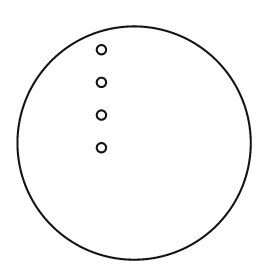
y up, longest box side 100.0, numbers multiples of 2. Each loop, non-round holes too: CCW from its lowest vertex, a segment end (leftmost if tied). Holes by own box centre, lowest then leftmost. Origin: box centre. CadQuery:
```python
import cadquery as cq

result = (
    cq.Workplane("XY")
    .moveTo(0.0, 0.0)
    .circle(50.0)
    .moveTo(-14.0, -2.0)
    .circle(2.0)
    .moveTo(-14.0, 12.0)
    .circle(2.0)
    .moveTo(-14.0, 26.0)
    .circle(2.0)
    .moveTo(-14.0, 40.0)
    .circle(2.0)
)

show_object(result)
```